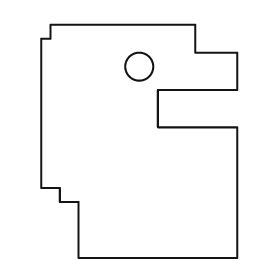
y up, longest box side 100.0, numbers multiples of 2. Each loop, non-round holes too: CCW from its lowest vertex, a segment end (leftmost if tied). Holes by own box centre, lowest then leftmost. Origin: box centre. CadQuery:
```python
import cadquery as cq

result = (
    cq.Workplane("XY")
    .moveTo(-26.0, -50.0)
    .lineTo(42.0, -50.0)
    .lineTo(42.0, 6.0)
    .lineTo(8.0, 6.0)
    .lineTo(8.0, 22.0)
    .lineTo(42.0, 22.0)
    .lineTo(42.0, 38.0)
    .lineTo(24.0, 38.0)
    .lineTo(24.0, 50.0)
    .lineTo(-38.0, 50.0)
    .lineTo(-38.0, 44.0)
    .lineTo(-42.0, 44.0)
    .lineTo(-42.0, -20.0)
    .lineTo(-34.0, -20.0)
    .lineTo(-34.0, -26.0)
    .lineTo(-26.0, -26.0)
    .close()
    .moveTo(0.0, 32.0)
    .circle(6.0)
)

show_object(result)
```